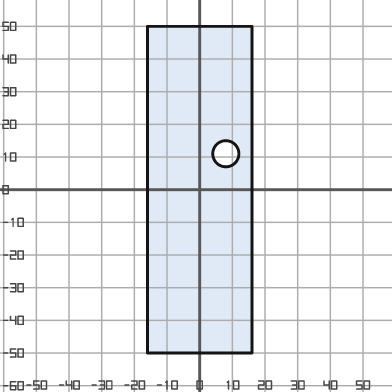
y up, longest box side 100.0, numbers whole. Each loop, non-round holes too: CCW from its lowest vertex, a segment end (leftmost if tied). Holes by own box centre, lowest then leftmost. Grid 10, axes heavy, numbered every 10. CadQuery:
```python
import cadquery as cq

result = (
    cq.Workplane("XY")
    .moveTo(-16.0, -50.0)
    .lineTo(16.0, -50.0)
    .lineTo(16.0, 50.0)
    .lineTo(-16.0, 50.0)
    .close()
    .moveTo(8.0, 11.0)
    .circle(4.0)
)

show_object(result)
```